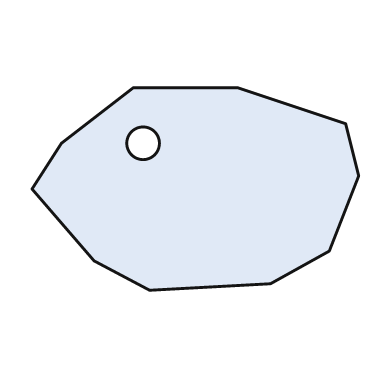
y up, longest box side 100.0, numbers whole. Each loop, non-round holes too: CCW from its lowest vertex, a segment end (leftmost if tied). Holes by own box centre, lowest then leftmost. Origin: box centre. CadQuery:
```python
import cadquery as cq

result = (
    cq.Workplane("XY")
    .moveTo(-14.0, -31.0)
    .lineTo(23.0, -29.0)
    .lineTo(41.0, -19.0)
    .lineTo(50.0, 4.0)
    .lineTo(46.0, 20.0)
    .lineTo(13.0, 31.0)
    .lineTo(-19.0, 31.0)
    .lineTo(-41.0, 14.0)
    .lineTo(-50.0, 0.0)
    .lineTo(-31.0, -22.0)
    .close()
    .moveTo(-16.0, 14.0)
    .circle(5.0)
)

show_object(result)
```